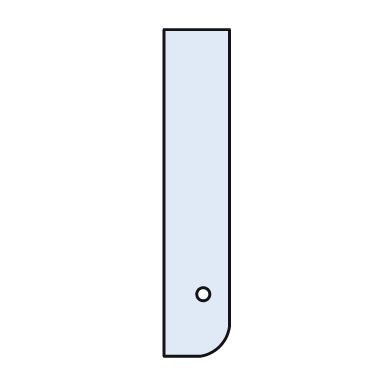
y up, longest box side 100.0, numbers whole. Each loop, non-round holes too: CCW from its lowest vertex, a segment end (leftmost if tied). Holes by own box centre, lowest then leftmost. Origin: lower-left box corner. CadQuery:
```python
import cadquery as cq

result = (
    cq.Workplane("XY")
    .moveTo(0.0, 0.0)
    .lineTo(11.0, 0.0)
    .threePointArc((17.0, 3.0), (20.0, 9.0))
    .lineTo(20.0, 100.0)
    .lineTo(0.0, 100.0)
    .close()
    .moveTo(12.0, 19.0)
    .circle(2.0)
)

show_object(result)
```